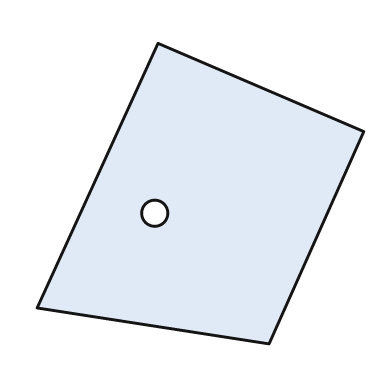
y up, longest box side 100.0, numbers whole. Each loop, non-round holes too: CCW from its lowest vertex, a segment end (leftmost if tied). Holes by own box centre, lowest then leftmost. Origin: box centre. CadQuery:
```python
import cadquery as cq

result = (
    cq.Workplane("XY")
    .moveTo(21.0, -46.0)
    .lineTo(50.0, 19.0)
    .lineTo(-13.0, 46.0)
    .lineTo(-50.0, -35.0)
    .close()
    .moveTo(-14.0, -6.0)
    .circle(4.0)
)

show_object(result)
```